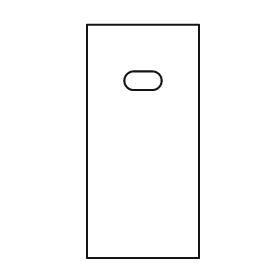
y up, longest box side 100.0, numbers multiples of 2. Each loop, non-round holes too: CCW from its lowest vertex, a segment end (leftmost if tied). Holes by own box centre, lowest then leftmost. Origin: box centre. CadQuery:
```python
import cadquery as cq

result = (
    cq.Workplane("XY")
    .moveTo(-24.0, -50.0)
    .lineTo(24.0, -50.0)
    .lineTo(24.0, 50.0)
    .lineTo(-24.0, 50.0)
    .close()
    .moveTo(-4.0, 22.0)
    .lineTo(4.0, 22.0)
    .threePointArc((8.0, 26.0), (4.0, 30.0))
    .lineTo(-4.0, 30.0)
    .threePointArc((-8.0, 26.0), (-4.0, 22.0))
    .close()
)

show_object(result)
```